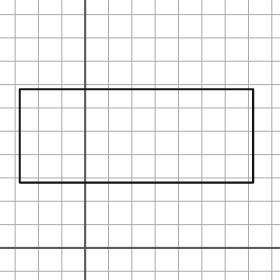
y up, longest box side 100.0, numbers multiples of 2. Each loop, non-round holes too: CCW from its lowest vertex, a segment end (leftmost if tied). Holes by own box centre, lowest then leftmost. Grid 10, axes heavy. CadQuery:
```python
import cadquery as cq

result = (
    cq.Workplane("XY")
    .moveTo(-28.0, 28.0)
    .lineTo(72.0, 28.0)
    .lineTo(72.0, 68.0)
    .lineTo(-28.0, 68.0)
    .close()
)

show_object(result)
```